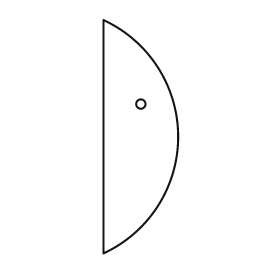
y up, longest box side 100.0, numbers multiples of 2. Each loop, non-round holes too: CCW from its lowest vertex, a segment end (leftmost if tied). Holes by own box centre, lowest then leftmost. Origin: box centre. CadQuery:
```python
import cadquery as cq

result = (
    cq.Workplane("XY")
    .moveTo(-16.0, -50.0)
    .threePointArc((16.0, 0.0), (-16.0, 50.0))
    .close()
    .moveTo(0.0, 14.0)
    .circle(2.0)
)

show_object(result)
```